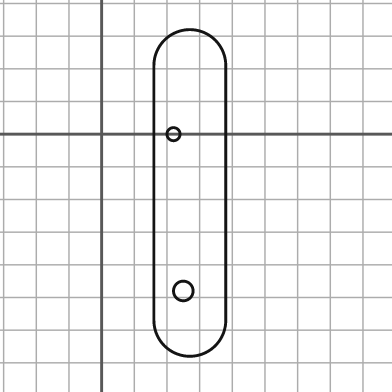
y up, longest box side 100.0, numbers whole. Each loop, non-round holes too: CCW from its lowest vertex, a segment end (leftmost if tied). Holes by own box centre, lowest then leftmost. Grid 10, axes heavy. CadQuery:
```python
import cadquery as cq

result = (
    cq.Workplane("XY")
    .moveTo(16.0, -57.0)
    .threePointArc((27.0, -68.0), (38.0, -57.0))
    .lineTo(38.0, 21.0)
    .threePointArc((27.0, 32.0), (16.0, 21.0))
    .close()
    .moveTo(25.0, -48.0)
    .circle(3.0)
    .moveTo(22.0, 0.0)
    .circle(2.0)
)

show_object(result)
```